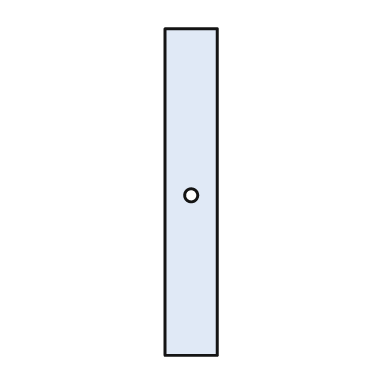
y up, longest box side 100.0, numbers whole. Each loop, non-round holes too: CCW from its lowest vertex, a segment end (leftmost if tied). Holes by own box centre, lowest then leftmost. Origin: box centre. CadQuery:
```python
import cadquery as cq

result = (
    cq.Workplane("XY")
    .moveTo(-8.0, -50.0)
    .lineTo(8.0, -50.0)
    .lineTo(8.0, 50.0)
    .lineTo(-8.0, 50.0)
    .close()
    .moveTo(0.0, -1.0)
    .circle(2.0)
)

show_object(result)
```